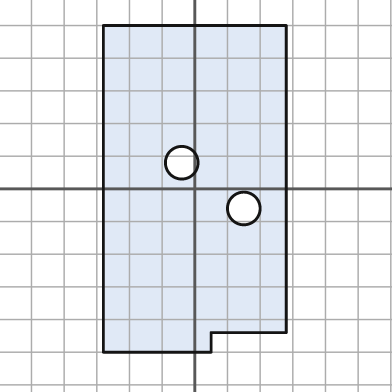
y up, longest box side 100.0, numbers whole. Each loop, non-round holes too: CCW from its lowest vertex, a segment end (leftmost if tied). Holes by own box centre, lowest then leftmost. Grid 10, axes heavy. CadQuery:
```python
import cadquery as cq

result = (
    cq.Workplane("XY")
    .moveTo(-28.0, -50.0)
    .lineTo(5.0, -50.0)
    .lineTo(5.0, -44.0)
    .lineTo(28.0, -44.0)
    .lineTo(28.0, 50.0)
    .lineTo(-28.0, 50.0)
    .close()
    .moveTo(15.0, -6.0)
    .circle(5.0)
    .moveTo(-4.0, 8.0)
    .circle(5.0)
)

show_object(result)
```